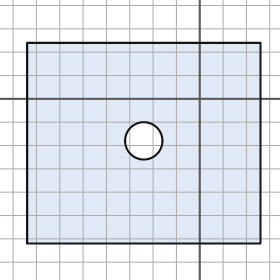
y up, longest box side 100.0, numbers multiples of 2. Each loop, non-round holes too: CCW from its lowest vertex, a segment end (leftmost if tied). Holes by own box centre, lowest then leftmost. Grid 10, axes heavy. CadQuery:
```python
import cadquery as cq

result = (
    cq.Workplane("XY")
    .moveTo(-74.0, -62.0)
    .lineTo(26.0, -62.0)
    .lineTo(26.0, 24.0)
    .lineTo(-74.0, 24.0)
    .close()
    .moveTo(-24.0, -18.0)
    .circle(8.0)
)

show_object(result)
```